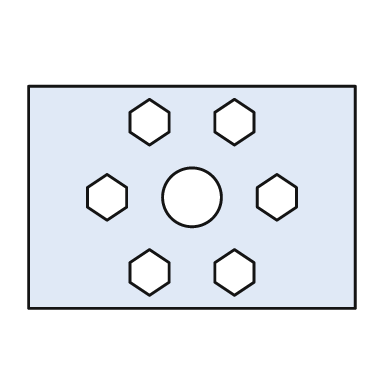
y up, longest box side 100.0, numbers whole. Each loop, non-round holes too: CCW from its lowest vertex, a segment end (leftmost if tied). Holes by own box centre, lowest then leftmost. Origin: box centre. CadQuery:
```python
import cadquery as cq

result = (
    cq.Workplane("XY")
    .moveTo(-50.0, -34.0)
    .lineTo(50.0, -34.0)
    .lineTo(50.0, 34.0)
    .lineTo(-50.0, 34.0)
    .close()
    .moveTo(-13.0, -30.0)
    .lineTo(-7.0, -26.0)
    .lineTo(-7.0, -20.0)
    .lineTo(-13.0, -16.0)
    .lineTo(-19.0, -20.0)
    .lineTo(-19.0, -26.0)
    .close()
    .moveTo(13.0, -30.0)
    .lineTo(19.0, -26.0)
    .lineTo(19.0, -20.0)
    .lineTo(13.0, -16.0)
    .lineTo(7.0, -20.0)
    .lineTo(7.0, -26.0)
    .close()
    .moveTo(-26.0, -7.0)
    .lineTo(-20.0, -3.0)
    .lineTo(-20.0, 3.0)
    .lineTo(-26.0, 7.0)
    .lineTo(-32.0, 3.0)
    .lineTo(-32.0, -3.0)
    .close()
    .moveTo(0.0, 0.0)
    .circle(9.0)
    .moveTo(26.0, -7.0)
    .lineTo(32.0, -3.0)
    .lineTo(32.0, 3.0)
    .lineTo(26.0, 7.0)
    .lineTo(20.0, 3.0)
    .lineTo(20.0, -3.0)
    .close()
    .moveTo(-13.0, 16.0)
    .lineTo(-7.0, 20.0)
    .lineTo(-7.0, 26.0)
    .lineTo(-13.0, 30.0)
    .lineTo(-19.0, 26.0)
    .lineTo(-19.0, 20.0)
    .close()
    .moveTo(13.0, 16.0)
    .lineTo(19.0, 20.0)
    .lineTo(19.0, 26.0)
    .lineTo(13.0, 30.0)
    .lineTo(7.0, 26.0)
    .lineTo(7.0, 20.0)
    .close()
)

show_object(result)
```